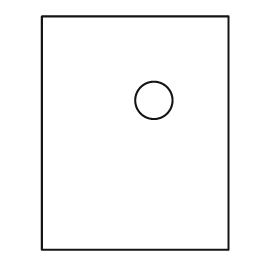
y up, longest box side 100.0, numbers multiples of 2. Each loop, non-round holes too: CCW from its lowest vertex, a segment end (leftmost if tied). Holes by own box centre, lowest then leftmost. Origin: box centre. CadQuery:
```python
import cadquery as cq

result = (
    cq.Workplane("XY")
    .moveTo(-40.0, -50.0)
    .lineTo(40.0, -50.0)
    .lineTo(40.0, 50.0)
    .lineTo(-40.0, 50.0)
    .close()
    .moveTo(8.0, 14.0)
    .circle(8.0)
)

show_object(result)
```